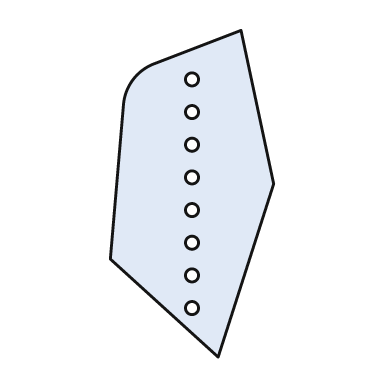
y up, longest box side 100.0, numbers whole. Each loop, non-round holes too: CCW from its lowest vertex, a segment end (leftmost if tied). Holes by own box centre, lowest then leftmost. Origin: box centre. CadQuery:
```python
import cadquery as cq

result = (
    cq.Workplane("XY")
    .moveTo(8.0, -50.0)
    .lineTo(25.0, 3.0)
    .lineTo(15.0, 50.0)
    .lineTo(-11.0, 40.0)
    .threePointArc((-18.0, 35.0), (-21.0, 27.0))
    .lineTo(-25.0, -20.0)
    .close()
    .moveTo(0.0, -35.0)
    .circle(2.0)
    .moveTo(0.0, -25.0)
    .circle(2.0)
    .moveTo(0.0, -15.0)
    .circle(2.0)
    .moveTo(0.0, -5.0)
    .circle(2.0)
    .moveTo(0.0, 5.0)
    .circle(2.0)
    .moveTo(0.0, 15.0)
    .circle(2.0)
    .moveTo(0.0, 25.0)
    .circle(2.0)
    .moveTo(0.0, 35.0)
    .circle(2.0)
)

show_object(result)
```